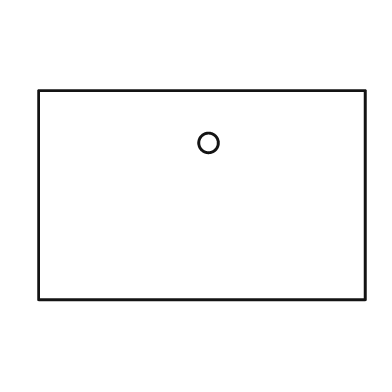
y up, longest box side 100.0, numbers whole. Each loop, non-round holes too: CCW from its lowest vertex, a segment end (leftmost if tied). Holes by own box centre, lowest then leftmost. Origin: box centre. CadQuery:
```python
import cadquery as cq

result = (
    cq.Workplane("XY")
    .moveTo(-50.0, -32.0)
    .lineTo(50.0, -32.0)
    .lineTo(50.0, 32.0)
    .lineTo(-50.0, 32.0)
    .close()
    .moveTo(2.0, 16.0)
    .circle(3.0)
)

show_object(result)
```